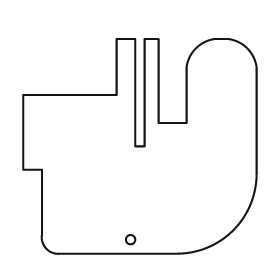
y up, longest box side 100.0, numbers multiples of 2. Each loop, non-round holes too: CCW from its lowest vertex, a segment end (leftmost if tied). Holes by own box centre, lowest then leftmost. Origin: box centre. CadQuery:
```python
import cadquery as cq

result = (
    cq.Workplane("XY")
    .moveTo(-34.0, -46.0)
    .lineTo(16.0, -46.0)
    .threePointArc((40.0, -36.0), (50.0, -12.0))
    .lineTo(50.0, 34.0)
    .threePointArc((46.0, 42.0), (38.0, 46.0))
    .lineTo(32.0, 46.0)
    .threePointArc((24.0, 42.0), (20.0, 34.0))
    .lineTo(20.0, 10.0)
    .lineTo(8.0, 10.0)
    .lineTo(8.0, 46.0)
    .lineTo(2.0, 46.0)
    .lineTo(2.0, 0.0)
    .lineTo(-2.0, 0.0)
    .lineTo(-2.0, 46.0)
    .lineTo(-10.0, 46.0)
    .lineTo(-10.0, 22.0)
    .lineTo(-50.0, 22.0)
    .lineTo(-50.0, -10.0)
    .lineTo(-42.0, -10.0)
    .lineTo(-42.0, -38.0)
    .threePointArc((-40.0, -44.0), (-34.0, -46.0))
    .close()
    .moveTo(-4.0, -40.0)
    .circle(2.0)
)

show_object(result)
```